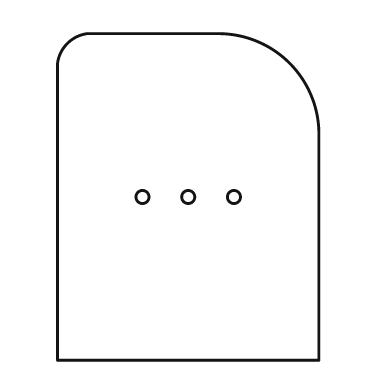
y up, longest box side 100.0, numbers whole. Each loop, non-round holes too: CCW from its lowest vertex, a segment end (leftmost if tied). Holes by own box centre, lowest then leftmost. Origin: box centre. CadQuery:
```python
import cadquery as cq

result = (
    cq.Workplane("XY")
    .moveTo(-40.0, -50.0)
    .lineTo(40.0, -50.0)
    .lineTo(40.0, 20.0)
    .threePointArc((31.0, 41.0), (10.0, 50.0))
    .lineTo(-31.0, 50.0)
    .threePointArc((-37.0, 47.0), (-40.0, 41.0))
    .close()
    .moveTo(-14.0, 0.0)
    .circle(2.0)
    .moveTo(0.0, 0.0)
    .circle(2.0)
    .moveTo(14.0, 0.0)
    .circle(2.0)
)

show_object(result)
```